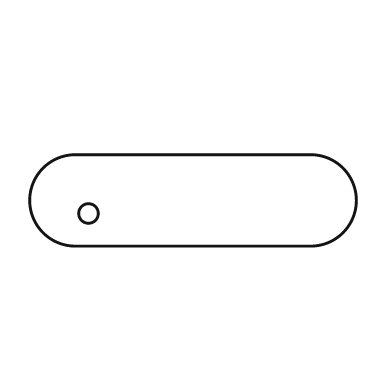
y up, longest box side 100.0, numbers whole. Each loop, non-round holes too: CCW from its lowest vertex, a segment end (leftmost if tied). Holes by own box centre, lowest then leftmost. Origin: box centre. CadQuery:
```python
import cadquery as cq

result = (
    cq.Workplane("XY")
    .moveTo(-36.0, -14.0)
    .lineTo(36.0, -14.0)
    .threePointArc((50.0, 0.0), (36.0, 14.0))
    .lineTo(-36.0, 14.0)
    .threePointArc((-50.0, 0.0), (-36.0, -14.0))
    .close()
    .moveTo(-32.0, -4.0)
    .circle(3.0)
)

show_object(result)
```